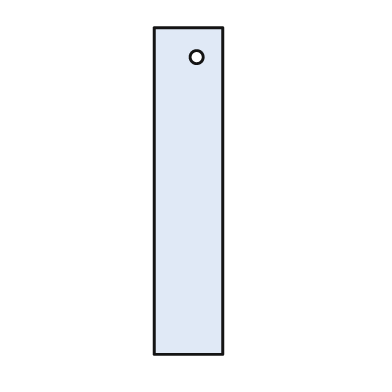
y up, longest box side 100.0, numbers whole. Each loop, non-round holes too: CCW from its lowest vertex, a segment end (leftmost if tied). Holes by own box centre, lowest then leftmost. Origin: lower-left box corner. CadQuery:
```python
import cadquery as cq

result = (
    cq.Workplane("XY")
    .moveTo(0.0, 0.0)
    .lineTo(21.0, 0.0)
    .lineTo(21.0, 100.0)
    .lineTo(0.0, 100.0)
    .close()
    .moveTo(13.0, 91.0)
    .circle(2.0)
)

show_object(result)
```